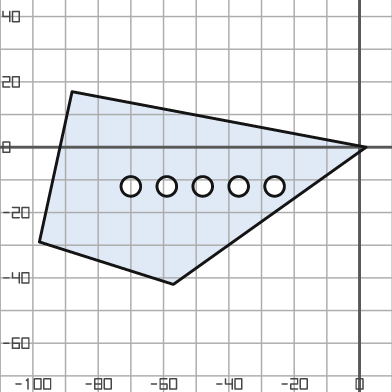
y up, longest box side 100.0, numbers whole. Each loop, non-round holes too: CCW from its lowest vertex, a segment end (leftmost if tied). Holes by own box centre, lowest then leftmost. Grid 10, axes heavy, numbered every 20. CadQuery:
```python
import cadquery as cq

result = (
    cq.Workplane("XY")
    .moveTo(-57.0, -42.0)
    .lineTo(2.0, 0.0)
    .lineTo(-88.0, 17.0)
    .lineTo(-98.0, -29.0)
    .close()
    .moveTo(-70.0, -12.0)
    .circle(3.0)
    .moveTo(-59.0, -12.0)
    .circle(3.0)
    .moveTo(-48.0, -12.0)
    .circle(3.0)
    .moveTo(-37.0, -12.0)
    .circle(3.0)
    .moveTo(-26.0, -12.0)
    .circle(3.0)
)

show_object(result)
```